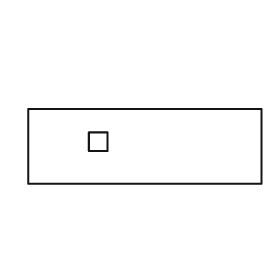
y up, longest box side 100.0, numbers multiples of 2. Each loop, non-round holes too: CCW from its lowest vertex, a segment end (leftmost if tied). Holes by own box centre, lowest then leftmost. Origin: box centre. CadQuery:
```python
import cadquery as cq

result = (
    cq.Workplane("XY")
    .moveTo(-50.0, -16.0)
    .lineTo(50.0, -16.0)
    .lineTo(50.0, 16.0)
    .lineTo(-50.0, 16.0)
    .close()
    .moveTo(-24.0, -2.0)
    .lineTo(-16.0, -2.0)
    .lineTo(-16.0, 6.0)
    .lineTo(-24.0, 6.0)
    .close()
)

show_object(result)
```